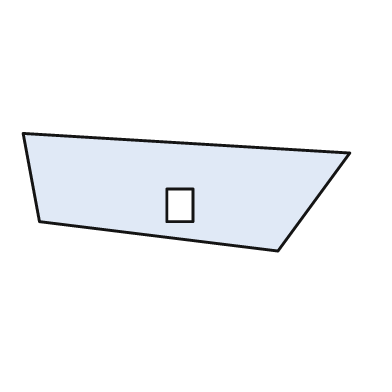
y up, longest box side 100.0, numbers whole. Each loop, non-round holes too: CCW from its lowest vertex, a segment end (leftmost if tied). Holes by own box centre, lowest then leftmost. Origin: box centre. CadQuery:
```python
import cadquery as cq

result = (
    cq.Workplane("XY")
    .moveTo(28.0, -18.0)
    .lineTo(50.0, 12.0)
    .lineTo(-50.0, 18.0)
    .lineTo(-45.0, -9.0)
    .close()
    .moveTo(-6.0, -9.0)
    .lineTo(2.0, -9.0)
    .lineTo(2.0, 1.0)
    .lineTo(-6.0, 1.0)
    .close()
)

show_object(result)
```